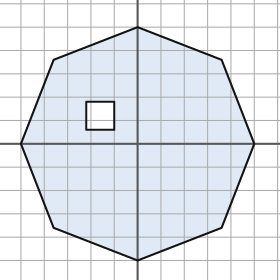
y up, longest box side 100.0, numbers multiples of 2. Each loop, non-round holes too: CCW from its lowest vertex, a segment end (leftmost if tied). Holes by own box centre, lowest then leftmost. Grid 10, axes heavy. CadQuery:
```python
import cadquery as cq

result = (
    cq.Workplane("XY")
    .moveTo(0.0, -50.0)
    .lineTo(36.0, -36.0)
    .lineTo(50.0, 0.0)
    .lineTo(36.0, 36.0)
    .lineTo(0.0, 50.0)
    .lineTo(-36.0, 36.0)
    .lineTo(-50.0, 0.0)
    .lineTo(-36.0, -36.0)
    .close()
    .moveTo(-22.0, 6.0)
    .lineTo(-10.0, 6.0)
    .lineTo(-10.0, 18.0)
    .lineTo(-22.0, 18.0)
    .close()
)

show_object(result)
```